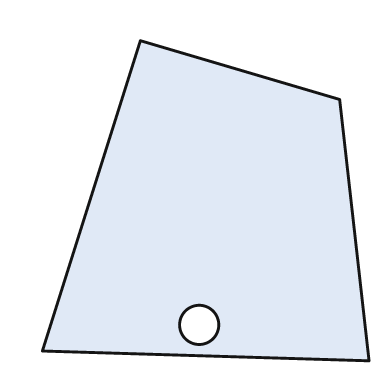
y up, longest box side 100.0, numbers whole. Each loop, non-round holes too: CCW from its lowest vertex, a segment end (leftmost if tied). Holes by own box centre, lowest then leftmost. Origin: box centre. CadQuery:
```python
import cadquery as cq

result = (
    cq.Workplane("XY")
    .moveTo(50.0, -49.0)
    .lineTo(41.0, 31.0)
    .lineTo(-20.0, 49.0)
    .lineTo(-50.0, -46.0)
    .close()
    .moveTo(-2.0, -38.0)
    .circle(6.0)
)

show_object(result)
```